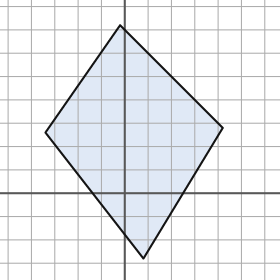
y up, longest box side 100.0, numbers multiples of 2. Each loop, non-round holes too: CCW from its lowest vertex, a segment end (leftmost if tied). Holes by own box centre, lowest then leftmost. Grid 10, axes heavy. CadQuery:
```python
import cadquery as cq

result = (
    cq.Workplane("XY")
    .moveTo(8.0, -28.0)
    .lineTo(42.0, 28.0)
    .lineTo(-2.0, 72.0)
    .lineTo(-34.0, 26.0)
    .close()
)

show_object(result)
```